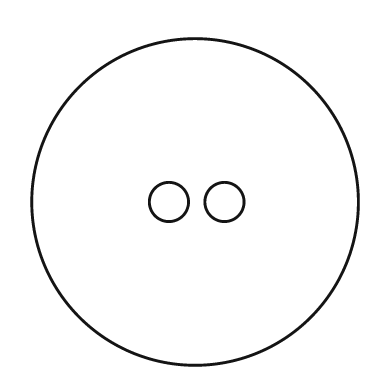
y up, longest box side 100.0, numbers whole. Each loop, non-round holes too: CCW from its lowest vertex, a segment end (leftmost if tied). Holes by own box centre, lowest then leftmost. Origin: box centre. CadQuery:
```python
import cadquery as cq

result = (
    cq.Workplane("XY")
    .moveTo(0.0, 0.0)
    .circle(50.0)
    .moveTo(-8.0, 0.0)
    .circle(6.0)
    .moveTo(9.0, 0.0)
    .circle(6.0)
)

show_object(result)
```